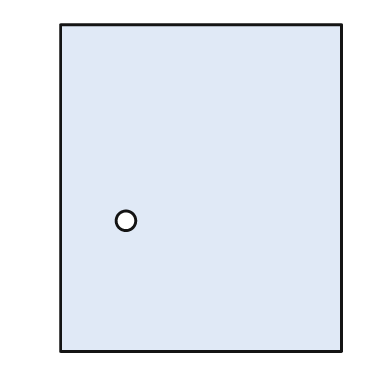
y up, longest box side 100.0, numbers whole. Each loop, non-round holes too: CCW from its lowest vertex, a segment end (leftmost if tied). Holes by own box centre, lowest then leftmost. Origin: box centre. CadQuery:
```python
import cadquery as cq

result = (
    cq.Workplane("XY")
    .moveTo(-43.0, -50.0)
    .lineTo(43.0, -50.0)
    .lineTo(43.0, 50.0)
    .lineTo(-43.0, 50.0)
    .close()
    .moveTo(-23.0, -10.0)
    .circle(3.0)
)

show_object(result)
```